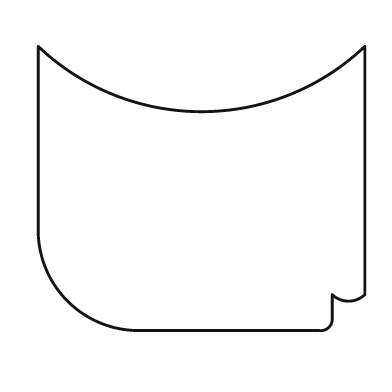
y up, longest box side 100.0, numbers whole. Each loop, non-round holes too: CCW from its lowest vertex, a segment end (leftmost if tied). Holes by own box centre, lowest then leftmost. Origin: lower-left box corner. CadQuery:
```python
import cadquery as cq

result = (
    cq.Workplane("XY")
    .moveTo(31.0, 0.0)
    .lineTo(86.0, 0.0)
    .threePointArc((89.0, 1.0), (90.0, 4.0))
    .lineTo(90.0, 11.0)
    .threePointArc((95.0, 9.0), (100.0, 11.0))
    .lineTo(100.0, 87.0)
    .threePointArc((50.0, 67.0), (0.0, 87.0))
    .lineTo(0.0, 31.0)
    .threePointArc((9.0, 9.0), (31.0, 0.0))
    .close()
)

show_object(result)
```